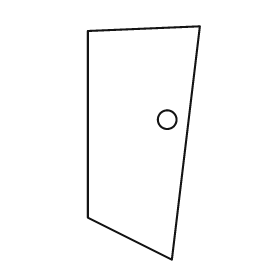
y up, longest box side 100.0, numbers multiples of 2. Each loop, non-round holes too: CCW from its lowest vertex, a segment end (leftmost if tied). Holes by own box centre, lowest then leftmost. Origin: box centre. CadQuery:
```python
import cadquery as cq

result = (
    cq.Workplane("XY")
    .moveTo(12.0, -50.0)
    .lineTo(24.0, 50.0)
    .lineTo(-24.0, 48.0)
    .lineTo(-24.0, -32.0)
    .close()
    .moveTo(10.0, 10.0)
    .circle(4.0)
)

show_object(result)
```